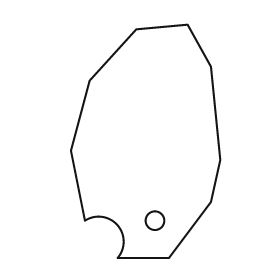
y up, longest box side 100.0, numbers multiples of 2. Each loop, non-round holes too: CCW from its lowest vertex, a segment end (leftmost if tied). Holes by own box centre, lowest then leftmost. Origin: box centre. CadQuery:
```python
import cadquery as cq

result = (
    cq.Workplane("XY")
    .moveTo(-12.0, -50.0)
    .lineTo(10.0, -50.0)
    .lineTo(28.0, -26.0)
    .lineTo(32.0, -8.0)
    .lineTo(28.0, 32.0)
    .lineTo(18.0, 50.0)
    .lineTo(-4.0, 48.0)
    .lineTo(-24.0, 26.0)
    .lineTo(-32.0, -4.0)
    .lineTo(-26.0, -34.0)
    .threePointArc((-12.0, -36.0), (-12.0, -50.0))
    .close()
    .moveTo(4.0, -34.0)
    .circle(4.0)
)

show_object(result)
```